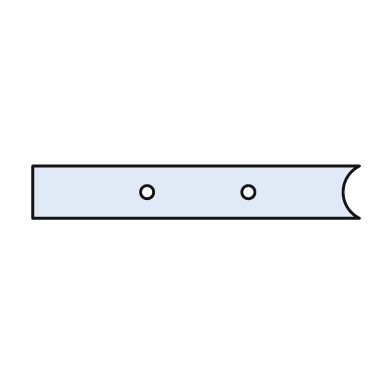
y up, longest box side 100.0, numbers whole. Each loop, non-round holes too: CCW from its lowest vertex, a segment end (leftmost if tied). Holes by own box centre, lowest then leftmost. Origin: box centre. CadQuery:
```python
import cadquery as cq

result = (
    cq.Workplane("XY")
    .moveTo(-50.0, -8.0)
    .lineTo(50.0, -8.0)
    .threePointArc((45.0, 0.0), (50.0, 8.0))
    .lineTo(-50.0, 8.0)
    .close()
    .moveTo(-15.0, 0.0)
    .circle(2.0)
    .moveTo(16.0, 0.0)
    .circle(2.0)
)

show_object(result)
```